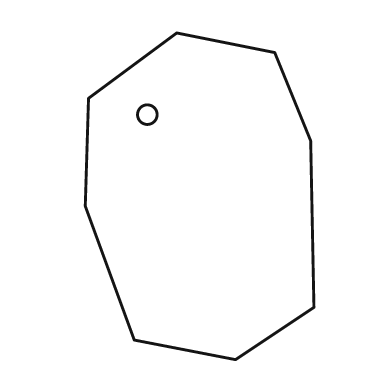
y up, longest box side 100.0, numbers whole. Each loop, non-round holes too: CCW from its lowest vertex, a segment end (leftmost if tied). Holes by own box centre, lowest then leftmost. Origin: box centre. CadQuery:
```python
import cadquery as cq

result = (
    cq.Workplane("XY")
    .moveTo(11.0, -50.0)
    .lineTo(35.0, -34.0)
    .lineTo(34.0, 17.0)
    .lineTo(23.0, 44.0)
    .lineTo(-7.0, 50.0)
    .lineTo(-34.0, 30.0)
    .lineTo(-35.0, -3.0)
    .lineTo(-20.0, -44.0)
    .close()
    .moveTo(-16.0, 25.0)
    .circle(3.0)
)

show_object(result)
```